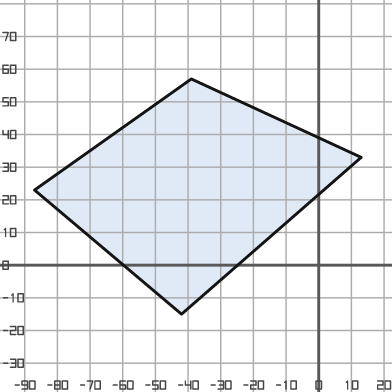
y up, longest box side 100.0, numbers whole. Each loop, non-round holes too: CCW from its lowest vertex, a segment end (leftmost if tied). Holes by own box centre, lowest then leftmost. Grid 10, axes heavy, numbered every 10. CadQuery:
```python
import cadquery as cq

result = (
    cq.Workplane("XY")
    .moveTo(-42.0, -15.0)
    .lineTo(13.0, 33.0)
    .lineTo(-39.0, 57.0)
    .lineTo(-87.0, 23.0)
    .close()
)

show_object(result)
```